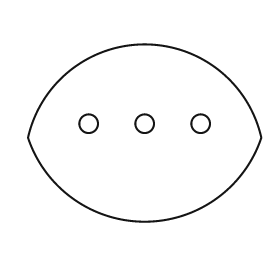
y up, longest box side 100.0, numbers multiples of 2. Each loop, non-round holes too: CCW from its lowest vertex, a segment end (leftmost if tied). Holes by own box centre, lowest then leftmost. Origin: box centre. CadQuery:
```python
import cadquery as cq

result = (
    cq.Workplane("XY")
    .moveTo(-50.0, -2.0)
    .threePointArc((0.0, -38.0), (50.0, -2.0))
    .threePointArc((0.0, 38.0), (-50.0, -2.0))
    .close()
    .moveTo(-24.0, 4.0)
    .circle(4.0)
    .moveTo(0.0, 4.0)
    .circle(4.0)
    .moveTo(24.0, 4.0)
    .circle(4.0)
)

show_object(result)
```